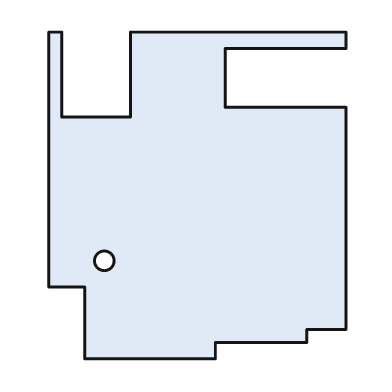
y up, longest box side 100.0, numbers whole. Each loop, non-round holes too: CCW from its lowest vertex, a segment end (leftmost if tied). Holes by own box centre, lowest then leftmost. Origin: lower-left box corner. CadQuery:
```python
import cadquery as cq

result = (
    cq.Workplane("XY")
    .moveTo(11.0, 0.0)
    .lineTo(51.0, 0.0)
    .lineTo(51.0, 5.0)
    .lineTo(79.0, 5.0)
    .lineTo(79.0, 9.0)
    .lineTo(91.0, 9.0)
    .lineTo(91.0, 77.0)
    .lineTo(54.0, 77.0)
    .lineTo(54.0, 95.0)
    .lineTo(91.0, 95.0)
    .lineTo(91.0, 100.0)
    .lineTo(25.0, 100.0)
    .lineTo(25.0, 74.0)
    .lineTo(4.0, 74.0)
    .lineTo(4.0, 100.0)
    .lineTo(0.0, 100.0)
    .lineTo(0.0, 22.0)
    .lineTo(11.0, 22.0)
    .close()
    .moveTo(17.0, 30.0)
    .circle(3.0)
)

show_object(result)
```